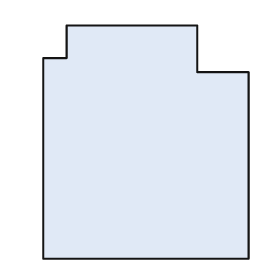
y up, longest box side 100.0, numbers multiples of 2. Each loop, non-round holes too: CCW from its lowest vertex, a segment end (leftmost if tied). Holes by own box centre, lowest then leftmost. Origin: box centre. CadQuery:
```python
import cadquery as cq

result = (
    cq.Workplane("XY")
    .moveTo(-44.0, -50.0)
    .lineTo(44.0, -50.0)
    .lineTo(44.0, 30.0)
    .lineTo(22.0, 30.0)
    .lineTo(22.0, 50.0)
    .lineTo(-34.0, 50.0)
    .lineTo(-34.0, 36.0)
    .lineTo(-44.0, 36.0)
    .close()
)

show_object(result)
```